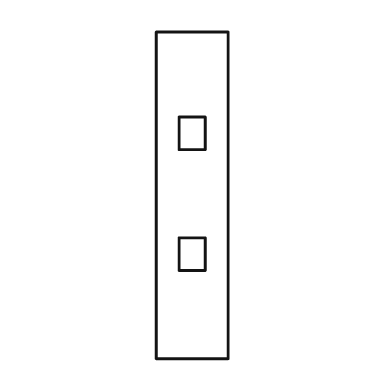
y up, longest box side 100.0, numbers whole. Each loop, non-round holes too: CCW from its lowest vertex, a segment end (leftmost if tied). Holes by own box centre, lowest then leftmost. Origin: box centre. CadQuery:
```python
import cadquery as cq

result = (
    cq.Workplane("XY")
    .moveTo(-11.0, -50.0)
    .lineTo(11.0, -50.0)
    .lineTo(11.0, 50.0)
    .lineTo(-11.0, 50.0)
    .close()
    .moveTo(-4.0, -23.0)
    .lineTo(4.0, -23.0)
    .lineTo(4.0, -13.0)
    .lineTo(-4.0, -13.0)
    .close()
    .moveTo(-4.0, 14.0)
    .lineTo(4.0, 14.0)
    .lineTo(4.0, 24.0)
    .lineTo(-4.0, 24.0)
    .close()
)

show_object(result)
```